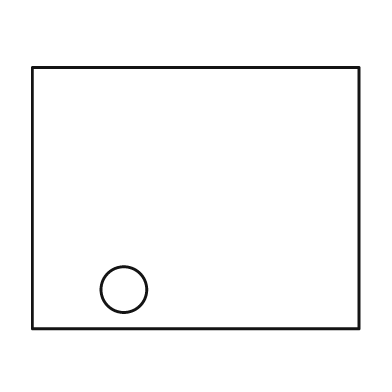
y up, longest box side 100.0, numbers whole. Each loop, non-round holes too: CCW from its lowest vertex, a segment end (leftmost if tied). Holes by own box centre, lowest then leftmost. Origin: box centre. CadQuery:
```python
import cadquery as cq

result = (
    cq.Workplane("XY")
    .moveTo(-50.0, -40.0)
    .lineTo(50.0, -40.0)
    .lineTo(50.0, 40.0)
    .lineTo(-50.0, 40.0)
    .close()
    .moveTo(-22.0, -28.0)
    .circle(7.0)
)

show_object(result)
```